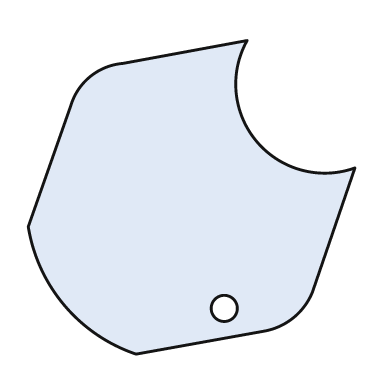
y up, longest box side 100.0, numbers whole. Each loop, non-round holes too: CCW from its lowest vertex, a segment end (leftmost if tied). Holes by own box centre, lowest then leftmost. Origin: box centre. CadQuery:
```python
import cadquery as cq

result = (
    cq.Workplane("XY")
    .moveTo(-17.0, -48.0)
    .lineTo(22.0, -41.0)
    .threePointArc((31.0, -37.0), (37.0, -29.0))
    .lineTo(50.0, 9.0)
    .threePointArc((20.0, 17.0), (17.0, 48.0))
    .lineTo(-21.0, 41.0)
    .threePointArc((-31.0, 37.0), (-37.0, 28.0))
    .lineTo(-50.0, -9.0)
    .threePointArc((-39.0, -33.0), (-17.0, -48.0))
    .close()
    .moveTo(10.0, -34.0)
    .circle(4.0)
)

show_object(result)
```